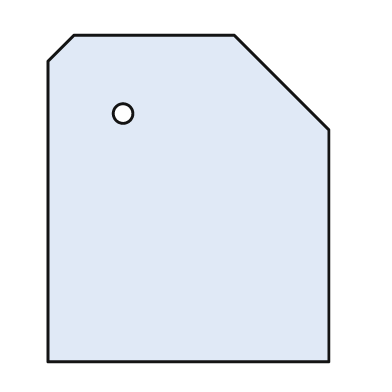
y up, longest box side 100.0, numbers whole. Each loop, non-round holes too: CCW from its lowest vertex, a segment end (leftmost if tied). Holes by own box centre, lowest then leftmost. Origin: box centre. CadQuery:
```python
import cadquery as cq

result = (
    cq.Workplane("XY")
    .moveTo(-43.0, -50.0)
    .lineTo(43.0, -50.0)
    .lineTo(43.0, 21.0)
    .lineTo(14.0, 50.0)
    .lineTo(-35.0, 50.0)
    .lineTo(-43.0, 42.0)
    .close()
    .moveTo(-20.0, 26.0)
    .circle(3.0)
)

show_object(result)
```